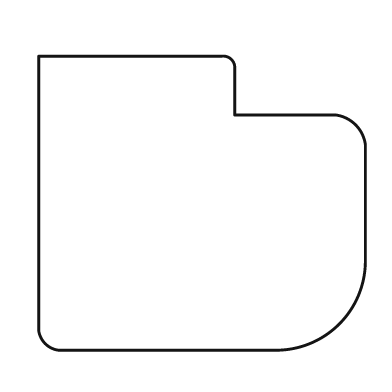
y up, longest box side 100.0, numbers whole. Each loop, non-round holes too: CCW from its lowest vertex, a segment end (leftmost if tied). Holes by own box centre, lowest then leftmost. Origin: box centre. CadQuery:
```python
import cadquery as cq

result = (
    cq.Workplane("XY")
    .moveTo(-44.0, -45.0)
    .lineTo(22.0, -45.0)
    .threePointArc((42.0, -37.0), (50.0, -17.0))
    .lineTo(50.0, 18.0)
    .threePointArc((47.0, 24.0), (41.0, 27.0))
    .lineTo(10.0, 27.0)
    .lineTo(10.0, 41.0)
    .threePointArc((9.0, 44.0), (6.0, 45.0))
    .lineTo(-50.0, 45.0)
    .lineTo(-50.0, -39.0)
    .threePointArc((-48.0, -43.0), (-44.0, -45.0))
    .close()
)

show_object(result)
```